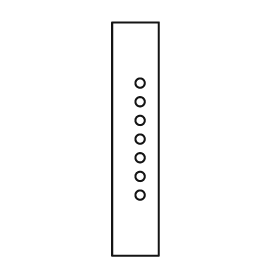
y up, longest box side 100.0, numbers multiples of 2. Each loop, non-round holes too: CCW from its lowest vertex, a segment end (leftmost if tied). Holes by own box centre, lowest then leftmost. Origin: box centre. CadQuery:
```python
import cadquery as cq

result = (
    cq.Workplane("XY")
    .moveTo(-10.0, -50.0)
    .lineTo(10.0, -50.0)
    .lineTo(10.0, 50.0)
    .lineTo(-10.0, 50.0)
    .close()
    .moveTo(2.0, -24.0)
    .circle(2.0)
    .moveTo(2.0, -16.0)
    .circle(2.0)
    .moveTo(2.0, -8.0)
    .circle(2.0)
    .moveTo(2.0, 0.0)
    .circle(2.0)
    .moveTo(2.0, 8.0)
    .circle(2.0)
    .moveTo(2.0, 16.0)
    .circle(2.0)
    .moveTo(2.0, 24.0)
    .circle(2.0)
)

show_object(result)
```